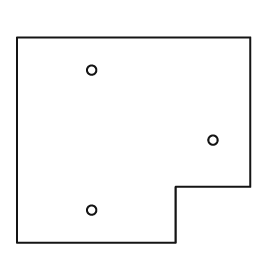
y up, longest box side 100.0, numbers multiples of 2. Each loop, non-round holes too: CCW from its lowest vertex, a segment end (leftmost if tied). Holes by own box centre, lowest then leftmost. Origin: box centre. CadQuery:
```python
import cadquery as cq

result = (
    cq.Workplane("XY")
    .moveTo(-50.0, -44.0)
    .lineTo(18.0, -44.0)
    .lineTo(18.0, -20.0)
    .lineTo(50.0, -20.0)
    .lineTo(50.0, 44.0)
    .lineTo(-50.0, 44.0)
    .close()
    .moveTo(-18.0, -30.0)
    .circle(2.0)
    .moveTo(34.0, 0.0)
    .circle(2.0)
    .moveTo(-18.0, 30.0)
    .circle(2.0)
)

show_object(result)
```